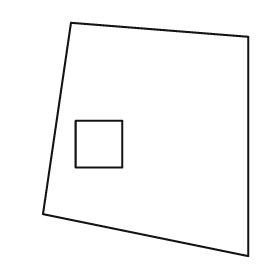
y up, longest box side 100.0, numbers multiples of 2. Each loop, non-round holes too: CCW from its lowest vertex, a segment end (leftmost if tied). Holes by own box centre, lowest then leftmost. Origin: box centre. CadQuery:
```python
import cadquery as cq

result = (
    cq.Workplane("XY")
    .moveTo(44.0, -50.0)
    .lineTo(44.0, 44.0)
    .lineTo(-32.0, 50.0)
    .lineTo(-44.0, -32.0)
    .close()
    .moveTo(-30.0, -12.0)
    .lineTo(-10.0, -12.0)
    .lineTo(-10.0, 8.0)
    .lineTo(-30.0, 8.0)
    .close()
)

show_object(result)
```